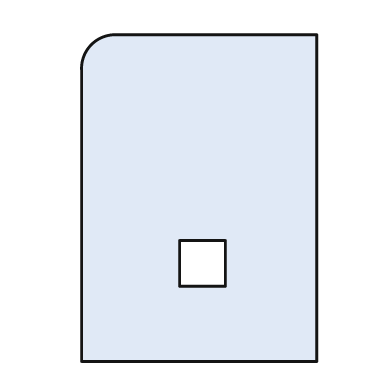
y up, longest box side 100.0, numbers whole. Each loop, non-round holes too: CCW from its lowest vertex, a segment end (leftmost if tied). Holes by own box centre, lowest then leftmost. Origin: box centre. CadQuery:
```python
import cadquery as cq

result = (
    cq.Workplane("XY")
    .moveTo(-36.0, -50.0)
    .lineTo(36.0, -50.0)
    .lineTo(36.0, 50.0)
    .lineTo(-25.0, 50.0)
    .threePointArc((-33.0, 47.0), (-36.0, 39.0))
    .close()
    .moveTo(-6.0, -27.0)
    .lineTo(8.0, -27.0)
    .lineTo(8.0, -13.0)
    .lineTo(-6.0, -13.0)
    .close()
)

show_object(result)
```